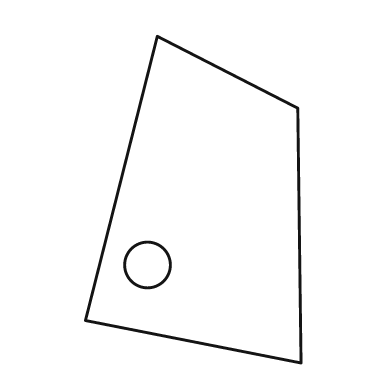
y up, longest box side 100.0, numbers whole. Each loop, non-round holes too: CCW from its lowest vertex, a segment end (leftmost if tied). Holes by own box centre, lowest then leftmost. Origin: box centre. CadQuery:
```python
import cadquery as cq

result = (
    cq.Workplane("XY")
    .moveTo(33.0, -50.0)
    .lineTo(32.0, 28.0)
    .lineTo(-11.0, 50.0)
    .lineTo(-33.0, -37.0)
    .close()
    .moveTo(-14.0, -20.0)
    .circle(7.0)
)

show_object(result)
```